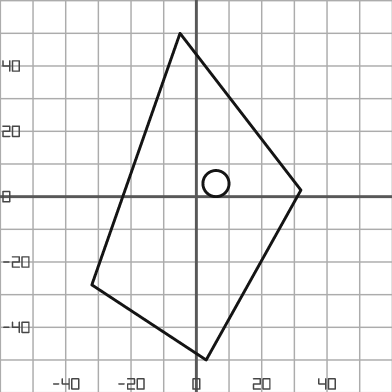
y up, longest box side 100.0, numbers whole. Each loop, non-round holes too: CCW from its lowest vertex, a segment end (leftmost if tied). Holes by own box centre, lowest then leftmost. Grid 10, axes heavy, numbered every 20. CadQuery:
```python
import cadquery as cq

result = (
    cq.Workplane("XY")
    .moveTo(3.0, -50.0)
    .lineTo(32.0, 2.0)
    .lineTo(-5.0, 50.0)
    .lineTo(-32.0, -27.0)
    .close()
    .moveTo(6.0, 4.0)
    .circle(4.0)
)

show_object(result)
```